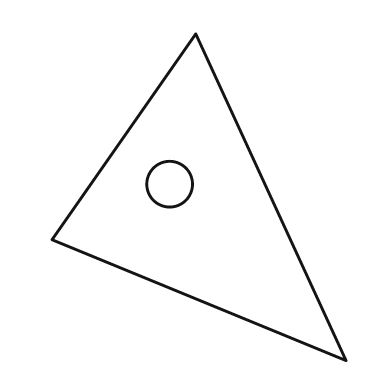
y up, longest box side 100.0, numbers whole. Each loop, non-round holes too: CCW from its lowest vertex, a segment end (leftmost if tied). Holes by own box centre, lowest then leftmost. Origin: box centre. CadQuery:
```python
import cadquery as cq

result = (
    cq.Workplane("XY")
    .moveTo(45.0, -50.0)
    .lineTo(-1.0, 50.0)
    .lineTo(-45.0, -13.0)
    .close()
    .moveTo(-9.0, 4.0)
    .circle(7.0)
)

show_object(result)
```